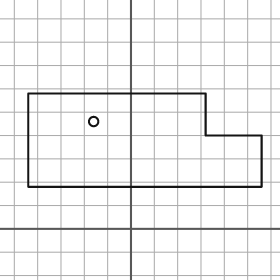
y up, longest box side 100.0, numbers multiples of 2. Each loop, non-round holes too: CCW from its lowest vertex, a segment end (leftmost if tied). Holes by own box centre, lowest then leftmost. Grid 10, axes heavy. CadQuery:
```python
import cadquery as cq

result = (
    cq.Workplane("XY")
    .moveTo(-44.0, 18.0)
    .lineTo(56.0, 18.0)
    .lineTo(56.0, 40.0)
    .lineTo(32.0, 40.0)
    .lineTo(32.0, 58.0)
    .lineTo(-44.0, 58.0)
    .close()
    .moveTo(-16.0, 46.0)
    .circle(2.0)
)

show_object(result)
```